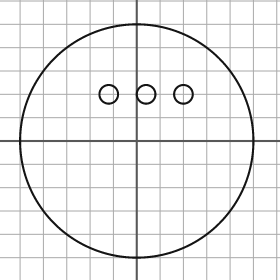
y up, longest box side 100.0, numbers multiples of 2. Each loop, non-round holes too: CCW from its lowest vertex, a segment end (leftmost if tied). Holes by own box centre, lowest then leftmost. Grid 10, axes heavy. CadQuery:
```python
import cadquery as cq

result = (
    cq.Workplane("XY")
    .moveTo(0.0, 0.0)
    .circle(50.0)
    .moveTo(-12.0, 20.0)
    .circle(4.0)
    .moveTo(4.0, 20.0)
    .circle(4.0)
    .moveTo(20.0, 20.0)
    .circle(4.0)
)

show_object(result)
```